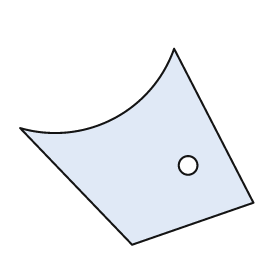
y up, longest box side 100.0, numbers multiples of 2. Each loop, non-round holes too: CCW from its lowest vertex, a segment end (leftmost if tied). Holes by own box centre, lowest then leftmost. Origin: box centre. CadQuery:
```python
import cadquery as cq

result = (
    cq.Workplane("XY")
    .moveTo(-2.0, -42.0)
    .lineTo(50.0, -24.0)
    .lineTo(16.0, 42.0)
    .threePointArc((-10.0, 12.0), (-50.0, 8.0))
    .close()
    .moveTo(22.0, -8.0)
    .circle(4.0)
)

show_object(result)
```